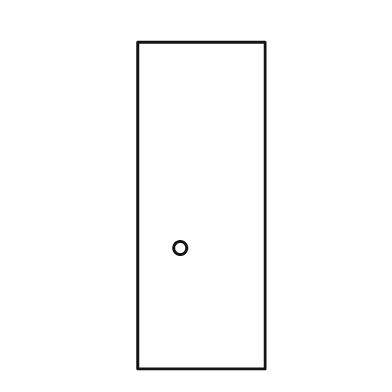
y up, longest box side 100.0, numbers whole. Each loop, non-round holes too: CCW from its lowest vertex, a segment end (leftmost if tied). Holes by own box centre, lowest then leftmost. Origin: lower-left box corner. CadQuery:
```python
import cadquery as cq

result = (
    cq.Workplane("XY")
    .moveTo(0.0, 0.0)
    .lineTo(39.0, 0.0)
    .lineTo(39.0, 100.0)
    .lineTo(0.0, 100.0)
    .close()
    .moveTo(13.0, 37.0)
    .circle(2.0)
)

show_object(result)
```